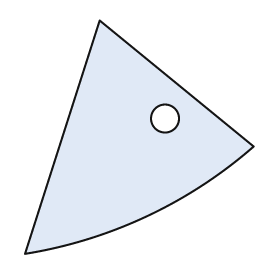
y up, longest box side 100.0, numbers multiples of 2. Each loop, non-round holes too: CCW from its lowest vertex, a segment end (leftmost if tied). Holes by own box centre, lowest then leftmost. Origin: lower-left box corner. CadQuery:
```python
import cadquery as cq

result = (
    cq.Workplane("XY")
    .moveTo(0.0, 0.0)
    .threePointArc((52.0, 16.0), (98.0, 46.0))
    .lineTo(32.0, 100.0)
    .close()
    .moveTo(60.0, 58.0)
    .circle(6.0)
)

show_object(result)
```